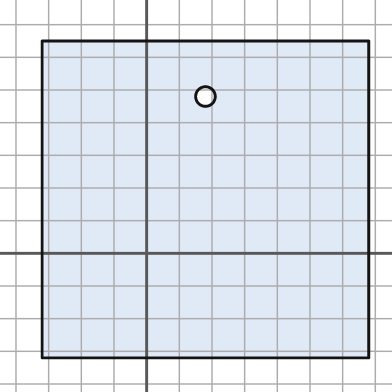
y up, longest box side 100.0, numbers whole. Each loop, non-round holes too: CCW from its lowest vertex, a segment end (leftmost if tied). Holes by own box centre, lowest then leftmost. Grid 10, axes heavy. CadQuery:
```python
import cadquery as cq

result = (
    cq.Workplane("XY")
    .moveTo(-32.0, -32.0)
    .lineTo(68.0, -32.0)
    .lineTo(68.0, 65.0)
    .lineTo(-32.0, 65.0)
    .close()
    .moveTo(18.0, 48.0)
    .circle(3.0)
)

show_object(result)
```